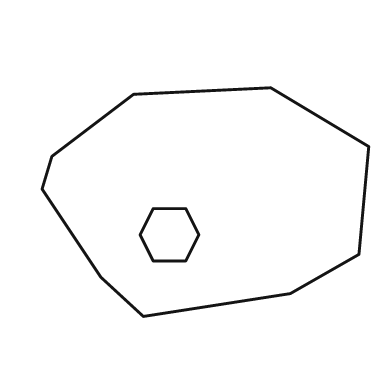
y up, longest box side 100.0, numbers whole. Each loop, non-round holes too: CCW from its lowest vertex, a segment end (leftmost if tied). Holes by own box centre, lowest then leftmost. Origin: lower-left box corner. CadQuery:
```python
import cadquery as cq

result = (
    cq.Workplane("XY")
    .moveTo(31.0, 0.0)
    .lineTo(76.0, 7.0)
    .lineTo(97.0, 19.0)
    .lineTo(100.0, 52.0)
    .lineTo(70.0, 70.0)
    .lineTo(28.0, 68.0)
    .lineTo(3.0, 49.0)
    .lineTo(0.0, 39.0)
    .lineTo(18.0, 12.0)
    .close()
    .moveTo(34.0, 17.0)
    .lineTo(44.0, 17.0)
    .lineTo(48.0, 25.0)
    .lineTo(44.0, 33.0)
    .lineTo(34.0, 33.0)
    .lineTo(30.0, 25.0)
    .close()
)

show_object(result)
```